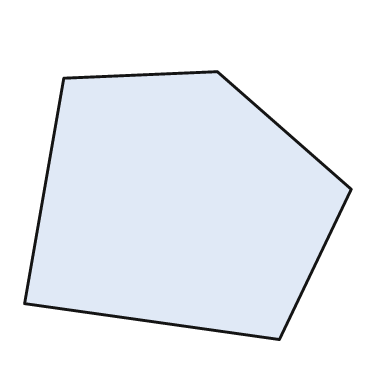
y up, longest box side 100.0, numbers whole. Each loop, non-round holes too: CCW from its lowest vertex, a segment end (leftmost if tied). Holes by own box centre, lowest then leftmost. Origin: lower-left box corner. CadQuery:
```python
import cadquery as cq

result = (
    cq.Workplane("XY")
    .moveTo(78.0, 0.0)
    .lineTo(100.0, 46.0)
    .lineTo(59.0, 82.0)
    .lineTo(12.0, 80.0)
    .lineTo(0.0, 11.0)
    .close()
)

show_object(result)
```